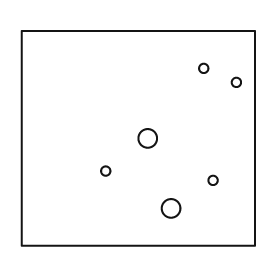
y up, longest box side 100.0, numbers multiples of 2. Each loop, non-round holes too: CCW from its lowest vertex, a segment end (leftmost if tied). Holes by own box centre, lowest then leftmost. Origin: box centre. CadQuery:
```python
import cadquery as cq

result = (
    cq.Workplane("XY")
    .moveTo(-50.0, -46.0)
    .lineTo(50.0, -46.0)
    .lineTo(50.0, 46.0)
    .lineTo(-50.0, 46.0)
    .close()
    .moveTo(14.0, -30.0)
    .circle(4.0)
    .moveTo(32.0, -18.0)
    .circle(2.0)
    .moveTo(-14.0, -14.0)
    .circle(2.0)
    .moveTo(4.0, 0.0)
    .circle(4.0)
    .moveTo(42.0, 24.0)
    .circle(2.0)
    .moveTo(28.0, 30.0)
    .circle(2.0)
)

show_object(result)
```